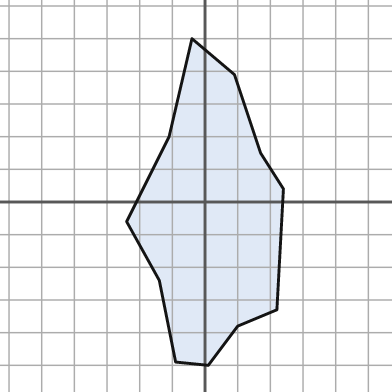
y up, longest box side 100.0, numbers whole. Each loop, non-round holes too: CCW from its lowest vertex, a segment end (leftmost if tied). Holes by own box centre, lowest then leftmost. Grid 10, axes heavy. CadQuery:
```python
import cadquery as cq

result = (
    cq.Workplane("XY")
    .moveTo(1.0, -50.0)
    .lineTo(10.0, -38.0)
    .lineTo(22.0, -33.0)
    .lineTo(24.0, 4.0)
    .lineTo(17.0, 15.0)
    .lineTo(9.0, 39.0)
    .lineTo(-4.0, 50.0)
    .lineTo(-11.0, 20.0)
    .lineTo(-24.0, -6.0)
    .lineTo(-14.0, -24.0)
    .lineTo(-9.0, -49.0)
    .close()
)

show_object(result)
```